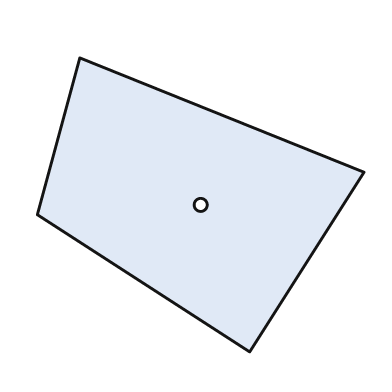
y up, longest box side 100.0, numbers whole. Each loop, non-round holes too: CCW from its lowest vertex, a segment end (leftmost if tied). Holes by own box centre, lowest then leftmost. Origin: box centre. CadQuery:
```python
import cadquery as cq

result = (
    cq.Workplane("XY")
    .moveTo(15.0, -45.0)
    .lineTo(50.0, 10.0)
    .lineTo(-37.0, 45.0)
    .lineTo(-50.0, -3.0)
    .close()
    .moveTo(0.0, 0.0)
    .circle(2.0)
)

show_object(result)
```